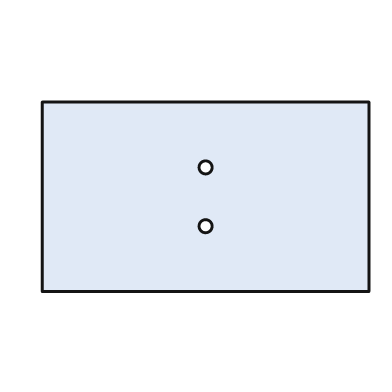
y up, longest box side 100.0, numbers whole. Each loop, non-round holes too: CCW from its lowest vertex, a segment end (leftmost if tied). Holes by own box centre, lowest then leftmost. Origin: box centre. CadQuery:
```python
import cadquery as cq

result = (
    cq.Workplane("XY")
    .moveTo(-50.0, -29.0)
    .lineTo(50.0, -29.0)
    .lineTo(50.0, 29.0)
    .lineTo(-50.0, 29.0)
    .close()
    .moveTo(0.0, -9.0)
    .circle(2.0)
    .moveTo(0.0, 9.0)
    .circle(2.0)
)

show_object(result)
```